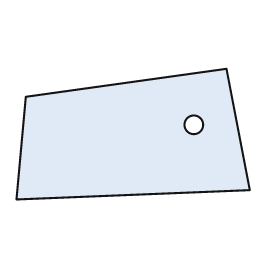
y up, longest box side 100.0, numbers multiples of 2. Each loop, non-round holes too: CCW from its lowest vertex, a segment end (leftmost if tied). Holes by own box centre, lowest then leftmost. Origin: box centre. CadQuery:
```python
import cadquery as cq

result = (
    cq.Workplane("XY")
    .moveTo(-50.0, -28.0)
    .lineTo(50.0, -24.0)
    .lineTo(40.0, 28.0)
    .lineTo(-46.0, 16.0)
    .close()
    .moveTo(26.0, 4.0)
    .circle(4.0)
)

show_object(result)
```